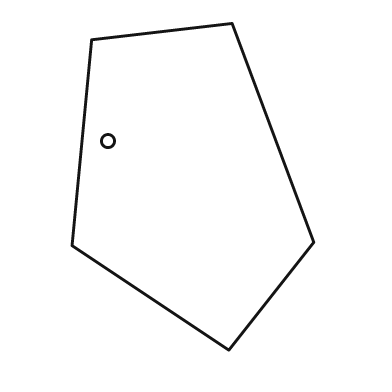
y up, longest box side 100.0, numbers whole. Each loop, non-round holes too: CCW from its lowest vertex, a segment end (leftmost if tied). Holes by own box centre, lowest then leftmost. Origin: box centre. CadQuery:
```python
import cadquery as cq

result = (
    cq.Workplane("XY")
    .moveTo(11.0, -50.0)
    .lineTo(37.0, -17.0)
    .lineTo(12.0, 50.0)
    .lineTo(-31.0, 45.0)
    .lineTo(-37.0, -18.0)
    .close()
    .moveTo(-26.0, 14.0)
    .circle(2.0)
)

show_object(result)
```